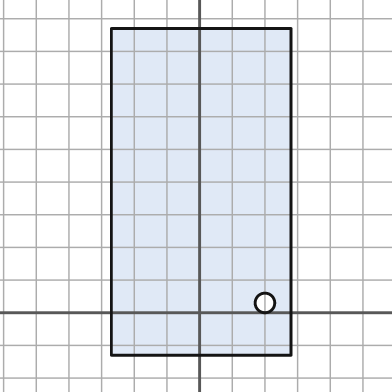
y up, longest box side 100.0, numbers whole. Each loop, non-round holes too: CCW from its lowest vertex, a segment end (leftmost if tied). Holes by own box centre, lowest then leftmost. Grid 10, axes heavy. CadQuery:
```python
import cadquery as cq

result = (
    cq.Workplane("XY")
    .moveTo(-27.0, -13.0)
    .lineTo(28.0, -13.0)
    .lineTo(28.0, 87.0)
    .lineTo(-27.0, 87.0)
    .close()
    .moveTo(20.0, 3.0)
    .circle(3.0)
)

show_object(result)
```